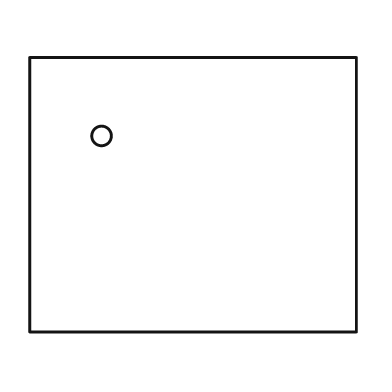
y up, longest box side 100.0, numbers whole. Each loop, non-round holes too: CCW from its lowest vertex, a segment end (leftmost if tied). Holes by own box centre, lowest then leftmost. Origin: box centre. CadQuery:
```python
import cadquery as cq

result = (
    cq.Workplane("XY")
    .moveTo(-50.0, -42.0)
    .lineTo(50.0, -42.0)
    .lineTo(50.0, 42.0)
    .lineTo(-50.0, 42.0)
    .close()
    .moveTo(-28.0, 18.0)
    .circle(3.0)
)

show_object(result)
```